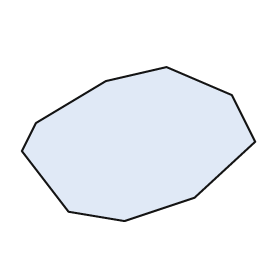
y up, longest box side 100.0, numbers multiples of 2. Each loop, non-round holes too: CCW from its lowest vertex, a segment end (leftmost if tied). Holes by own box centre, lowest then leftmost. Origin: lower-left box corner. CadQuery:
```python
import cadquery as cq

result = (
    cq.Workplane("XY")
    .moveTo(44.0, 0.0)
    .lineTo(74.0, 10.0)
    .lineTo(100.0, 34.0)
    .lineTo(90.0, 54.0)
    .lineTo(62.0, 66.0)
    .lineTo(36.0, 60.0)
    .lineTo(6.0, 42.0)
    .lineTo(0.0, 30.0)
    .lineTo(20.0, 4.0)
    .close()
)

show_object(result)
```